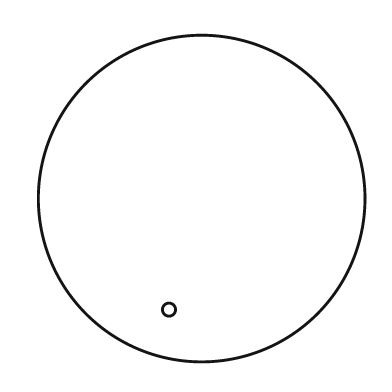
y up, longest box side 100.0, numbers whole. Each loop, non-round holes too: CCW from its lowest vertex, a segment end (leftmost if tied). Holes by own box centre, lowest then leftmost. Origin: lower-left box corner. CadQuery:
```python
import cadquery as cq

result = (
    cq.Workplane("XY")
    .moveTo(50.0, 50.0)
    .circle(50.0)
    .moveTo(40.0, 16.0)
    .circle(2.0)
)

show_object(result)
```